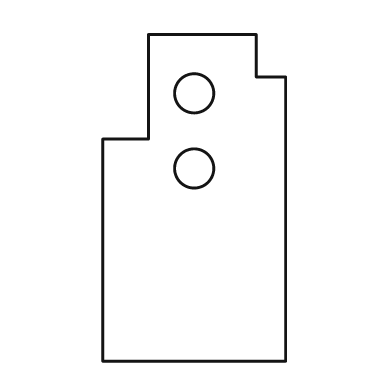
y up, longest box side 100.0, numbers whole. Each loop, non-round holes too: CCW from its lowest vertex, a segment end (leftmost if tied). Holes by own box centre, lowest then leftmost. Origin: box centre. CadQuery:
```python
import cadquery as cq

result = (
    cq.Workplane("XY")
    .moveTo(-28.0, -50.0)
    .lineTo(28.0, -50.0)
    .lineTo(28.0, 37.0)
    .lineTo(19.0, 37.0)
    .lineTo(19.0, 50.0)
    .lineTo(-14.0, 50.0)
    .lineTo(-14.0, 18.0)
    .lineTo(-28.0, 18.0)
    .close()
    .moveTo(0.0, 9.0)
    .circle(6.0)
    .moveTo(0.0, 32.0)
    .circle(6.0)
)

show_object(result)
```